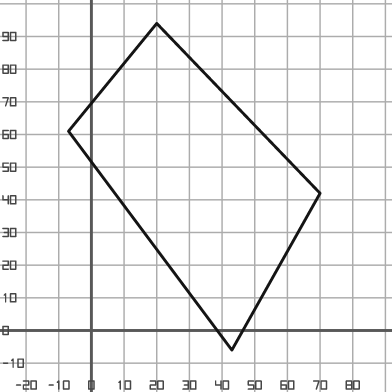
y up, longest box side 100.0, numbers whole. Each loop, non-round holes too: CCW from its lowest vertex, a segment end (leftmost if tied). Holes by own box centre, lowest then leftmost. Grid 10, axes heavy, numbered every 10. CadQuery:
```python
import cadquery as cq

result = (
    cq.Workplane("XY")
    .moveTo(43.0, -6.0)
    .lineTo(70.0, 42.0)
    .lineTo(20.0, 94.0)
    .lineTo(-7.0, 61.0)
    .close()
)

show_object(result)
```